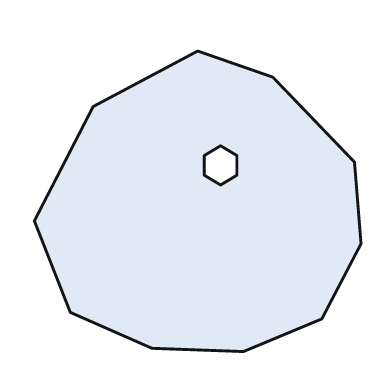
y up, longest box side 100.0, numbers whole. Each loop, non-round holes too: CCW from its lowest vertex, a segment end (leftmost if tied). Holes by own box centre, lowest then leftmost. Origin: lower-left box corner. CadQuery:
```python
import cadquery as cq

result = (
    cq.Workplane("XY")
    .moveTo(64.0, 0.0)
    .lineTo(88.0, 10.0)
    .lineTo(100.0, 33.0)
    .lineTo(98.0, 58.0)
    .lineTo(73.0, 84.0)
    .lineTo(50.0, 92.0)
    .lineTo(18.0, 75.0)
    .lineTo(0.0, 40.0)
    .lineTo(11.0, 12.0)
    .lineTo(36.0, 1.0)
    .close()
    .moveTo(57.0, 51.0)
    .lineTo(62.0, 54.0)
    .lineTo(62.0, 60.0)
    .lineTo(57.0, 63.0)
    .lineTo(52.0, 60.0)
    .lineTo(52.0, 54.0)
    .close()
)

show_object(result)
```